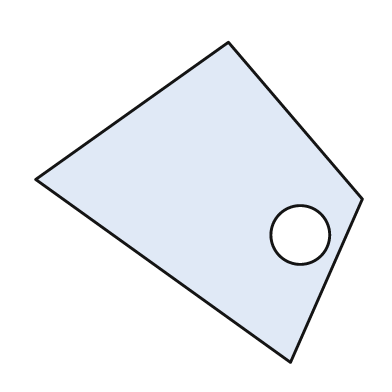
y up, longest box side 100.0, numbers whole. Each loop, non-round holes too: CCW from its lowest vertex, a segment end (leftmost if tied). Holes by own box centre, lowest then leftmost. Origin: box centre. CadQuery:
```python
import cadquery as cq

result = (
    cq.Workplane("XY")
    .moveTo(28.0, -49.0)
    .lineTo(50.0, 1.0)
    .lineTo(9.0, 49.0)
    .lineTo(-50.0, 7.0)
    .close()
    .moveTo(31.0, -10.0)
    .circle(9.0)
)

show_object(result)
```